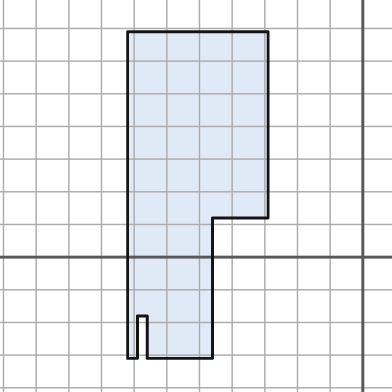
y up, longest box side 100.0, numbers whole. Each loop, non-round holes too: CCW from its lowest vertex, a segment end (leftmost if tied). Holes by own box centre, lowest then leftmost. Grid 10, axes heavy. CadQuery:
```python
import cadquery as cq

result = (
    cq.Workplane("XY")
    .moveTo(-72.0, -31.0)
    .lineTo(-69.0, -31.0)
    .lineTo(-69.0, -18.0)
    .lineTo(-66.0, -18.0)
    .lineTo(-66.0, -31.0)
    .lineTo(-46.0, -31.0)
    .lineTo(-46.0, 12.0)
    .lineTo(-29.0, 12.0)
    .lineTo(-29.0, 69.0)
    .lineTo(-72.0, 69.0)
    .close()
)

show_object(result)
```